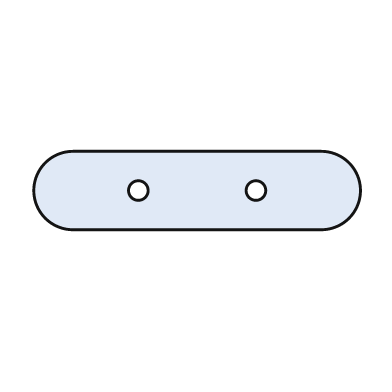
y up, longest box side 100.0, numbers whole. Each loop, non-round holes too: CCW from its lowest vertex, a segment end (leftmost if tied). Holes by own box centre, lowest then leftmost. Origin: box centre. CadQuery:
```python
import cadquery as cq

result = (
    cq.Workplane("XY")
    .moveTo(-38.0, -12.0)
    .lineTo(38.0, -12.0)
    .threePointArc((50.0, 0.0), (38.0, 12.0))
    .lineTo(-38.0, 12.0)
    .threePointArc((-50.0, 0.0), (-38.0, -12.0))
    .close()
    .moveTo(-18.0, 0.0)
    .circle(3.0)
    .moveTo(18.0, 0.0)
    .circle(3.0)
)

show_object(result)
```